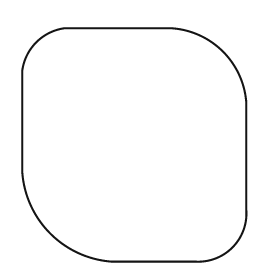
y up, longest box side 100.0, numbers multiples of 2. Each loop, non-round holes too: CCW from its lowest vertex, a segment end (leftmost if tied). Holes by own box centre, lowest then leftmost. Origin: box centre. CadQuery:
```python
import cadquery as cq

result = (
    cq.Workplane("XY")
    .moveTo(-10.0, -50.0)
    .lineTo(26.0, -50.0)
    .threePointArc((42.0, -44.0), (48.0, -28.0))
    .lineTo(48.0, 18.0)
    .threePointArc((38.0, 40.0), (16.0, 50.0))
    .lineTo(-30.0, 50.0)
    .threePointArc((-42.0, 44.0), (-48.0, 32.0))
    .lineTo(-48.0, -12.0)
    .threePointArc((-36.0, -38.0), (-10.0, -50.0))
    .close()
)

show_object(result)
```